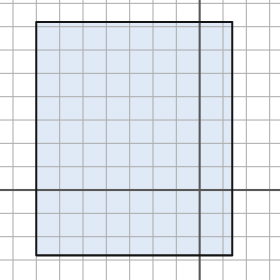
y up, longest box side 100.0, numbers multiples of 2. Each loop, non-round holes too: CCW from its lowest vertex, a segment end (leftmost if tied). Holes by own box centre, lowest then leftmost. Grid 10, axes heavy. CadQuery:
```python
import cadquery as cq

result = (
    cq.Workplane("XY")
    .moveTo(-70.0, -28.0)
    .lineTo(14.0, -28.0)
    .lineTo(14.0, 72.0)
    .lineTo(-70.0, 72.0)
    .close()
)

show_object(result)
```